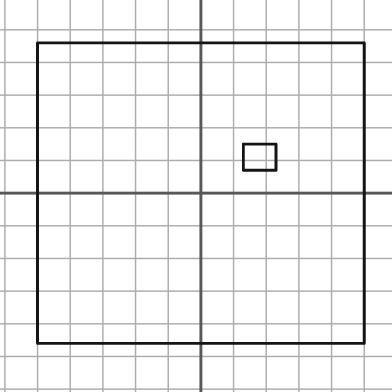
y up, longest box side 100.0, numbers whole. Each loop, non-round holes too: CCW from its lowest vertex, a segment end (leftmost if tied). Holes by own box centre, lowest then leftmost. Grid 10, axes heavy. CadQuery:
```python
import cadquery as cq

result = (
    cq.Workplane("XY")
    .moveTo(-50.0, -46.0)
    .lineTo(50.0, -46.0)
    .lineTo(50.0, 46.0)
    .lineTo(-50.0, 46.0)
    .close()
    .moveTo(13.0, 7.0)
    .lineTo(23.0, 7.0)
    .lineTo(23.0, 15.0)
    .lineTo(13.0, 15.0)
    .close()
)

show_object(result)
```